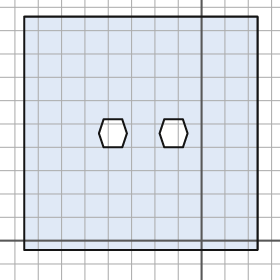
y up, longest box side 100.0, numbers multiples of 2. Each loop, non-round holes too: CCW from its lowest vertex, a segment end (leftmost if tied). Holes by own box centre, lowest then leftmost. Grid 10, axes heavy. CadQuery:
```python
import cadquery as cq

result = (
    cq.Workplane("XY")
    .moveTo(-76.0, -4.0)
    .lineTo(24.0, -4.0)
    .lineTo(24.0, 96.0)
    .lineTo(-76.0, 96.0)
    .close()
    .moveTo(-42.0, 40.0)
    .lineTo(-34.0, 40.0)
    .lineTo(-32.0, 46.0)
    .lineTo(-34.0, 52.0)
    .lineTo(-42.0, 52.0)
    .lineTo(-44.0, 46.0)
    .close()
    .moveTo(-16.0, 40.0)
    .lineTo(-8.0, 40.0)
    .lineTo(-6.0, 46.0)
    .lineTo(-8.0, 52.0)
    .lineTo(-16.0, 52.0)
    .lineTo(-18.0, 46.0)
    .close()
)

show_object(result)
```